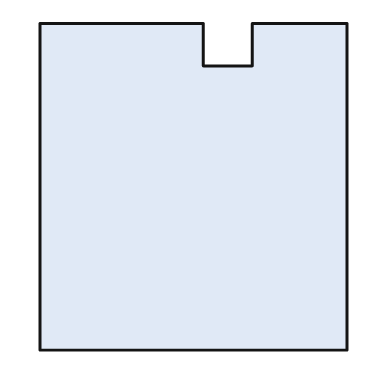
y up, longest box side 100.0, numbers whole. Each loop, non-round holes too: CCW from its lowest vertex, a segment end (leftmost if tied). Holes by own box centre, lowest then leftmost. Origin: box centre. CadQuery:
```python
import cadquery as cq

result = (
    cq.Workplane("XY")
    .moveTo(-47.0, -50.0)
    .lineTo(47.0, -50.0)
    .lineTo(47.0, 50.0)
    .lineTo(18.0, 50.0)
    .lineTo(18.0, 37.0)
    .lineTo(3.0, 37.0)
    .lineTo(3.0, 50.0)
    .lineTo(-47.0, 50.0)
    .close()
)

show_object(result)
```